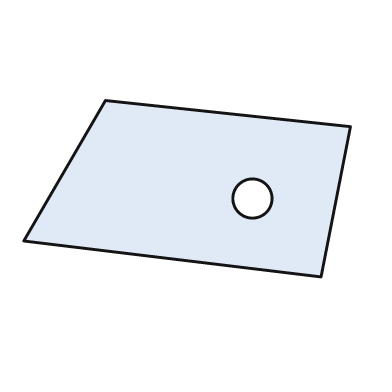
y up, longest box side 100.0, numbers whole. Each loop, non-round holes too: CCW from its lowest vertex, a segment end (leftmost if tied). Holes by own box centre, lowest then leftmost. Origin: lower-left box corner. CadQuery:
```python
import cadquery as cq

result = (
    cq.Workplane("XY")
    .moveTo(91.0, 0.0)
    .lineTo(100.0, 46.0)
    .lineTo(25.0, 54.0)
    .lineTo(0.0, 11.0)
    .close()
    .moveTo(70.0, 24.0)
    .circle(6.0)
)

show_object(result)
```